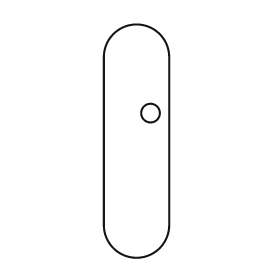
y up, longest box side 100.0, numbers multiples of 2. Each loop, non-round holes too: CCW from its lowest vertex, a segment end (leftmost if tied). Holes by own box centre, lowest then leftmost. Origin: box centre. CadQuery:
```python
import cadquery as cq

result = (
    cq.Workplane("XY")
    .moveTo(-14.0, -36.0)
    .threePointArc((0.0, -50.0), (14.0, -36.0))
    .lineTo(14.0, 36.0)
    .threePointArc((0.0, 50.0), (-14.0, 36.0))
    .close()
    .moveTo(6.0, 12.0)
    .circle(4.0)
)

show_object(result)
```